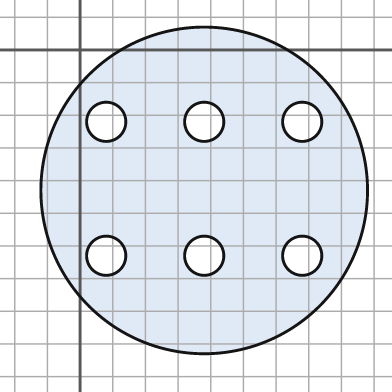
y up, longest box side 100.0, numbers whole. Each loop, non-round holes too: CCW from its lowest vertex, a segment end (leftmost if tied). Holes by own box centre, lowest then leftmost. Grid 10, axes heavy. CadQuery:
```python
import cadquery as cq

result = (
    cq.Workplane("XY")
    .moveTo(38.0, -43.0)
    .circle(50.0)
    .moveTo(8.0, -63.0)
    .circle(6.0)
    .moveTo(38.0, -63.0)
    .circle(6.0)
    .moveTo(68.0, -63.0)
    .circle(6.0)
    .moveTo(8.0, -22.0)
    .circle(6.0)
    .moveTo(38.0, -22.0)
    .circle(6.0)
    .moveTo(68.0, -22.0)
    .circle(6.0)
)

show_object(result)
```